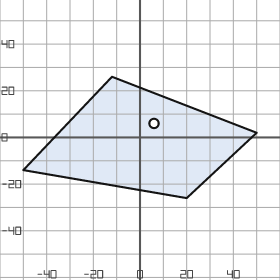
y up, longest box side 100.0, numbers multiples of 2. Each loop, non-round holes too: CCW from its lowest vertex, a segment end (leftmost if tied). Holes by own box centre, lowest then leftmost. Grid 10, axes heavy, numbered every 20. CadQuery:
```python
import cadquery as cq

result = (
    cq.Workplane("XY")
    .moveTo(20.0, -26.0)
    .lineTo(50.0, 2.0)
    .lineTo(-12.0, 26.0)
    .lineTo(-50.0, -14.0)
    .close()
    .moveTo(6.0, 6.0)
    .circle(2.0)
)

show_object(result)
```